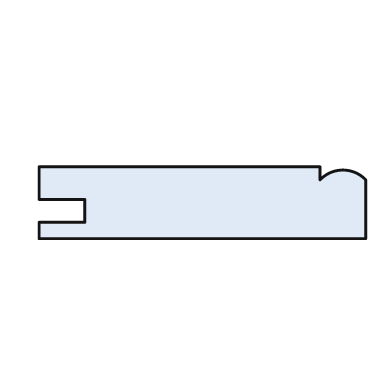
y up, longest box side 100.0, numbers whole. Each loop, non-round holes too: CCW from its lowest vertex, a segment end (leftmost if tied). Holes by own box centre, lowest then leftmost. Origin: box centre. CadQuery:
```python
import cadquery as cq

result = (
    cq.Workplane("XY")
    .moveTo(-50.0, -11.0)
    .lineTo(50.0, -11.0)
    .lineTo(50.0, 7.0)
    .threePointArc((43.0, 10.0), (36.0, 7.0))
    .lineTo(36.0, 11.0)
    .lineTo(-50.0, 11.0)
    .lineTo(-50.0, 1.0)
    .lineTo(-36.0, 1.0)
    .lineTo(-36.0, -6.0)
    .lineTo(-50.0, -6.0)
    .close()
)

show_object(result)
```